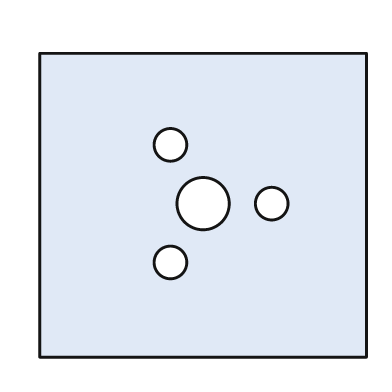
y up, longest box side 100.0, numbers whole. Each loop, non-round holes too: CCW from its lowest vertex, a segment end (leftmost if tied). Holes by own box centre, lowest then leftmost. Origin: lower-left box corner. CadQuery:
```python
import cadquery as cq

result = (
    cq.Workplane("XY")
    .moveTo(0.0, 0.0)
    .lineTo(100.0, 0.0)
    .lineTo(100.0, 93.0)
    .lineTo(0.0, 93.0)
    .close()
    .moveTo(40.0, 29.0)
    .circle(5.0)
    .moveTo(50.0, 47.0)
    .circle(8.0)
    .moveTo(71.0, 47.0)
    .circle(5.0)
    .moveTo(40.0, 65.0)
    .circle(5.0)
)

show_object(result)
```